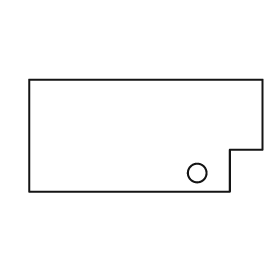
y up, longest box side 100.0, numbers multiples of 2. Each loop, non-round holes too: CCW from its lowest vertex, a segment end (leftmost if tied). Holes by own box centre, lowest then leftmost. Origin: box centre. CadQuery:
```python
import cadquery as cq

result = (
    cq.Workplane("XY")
    .moveTo(-50.0, -24.0)
    .lineTo(36.0, -24.0)
    .lineTo(36.0, -6.0)
    .lineTo(50.0, -6.0)
    .lineTo(50.0, 24.0)
    .lineTo(-50.0, 24.0)
    .close()
    .moveTo(22.0, -16.0)
    .circle(4.0)
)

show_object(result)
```